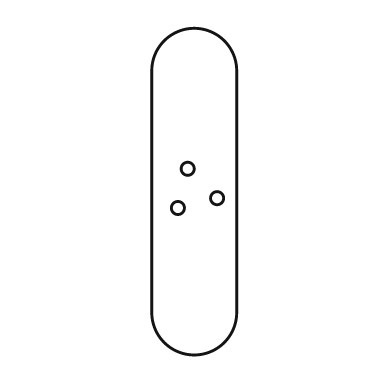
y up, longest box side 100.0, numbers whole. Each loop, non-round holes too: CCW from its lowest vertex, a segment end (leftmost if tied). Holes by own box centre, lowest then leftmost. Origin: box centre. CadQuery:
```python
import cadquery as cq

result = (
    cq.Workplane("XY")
    .moveTo(-13.0, -37.0)
    .threePointArc((0.0, -50.0), (13.0, -37.0))
    .lineTo(13.0, 37.0)
    .threePointArc((0.0, 50.0), (-13.0, 37.0))
    .close()
    .moveTo(-5.0, -5.0)
    .circle(2.0)
    .moveTo(7.0, -2.0)
    .circle(2.0)
    .moveTo(-2.0, 7.0)
    .circle(2.0)
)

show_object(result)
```